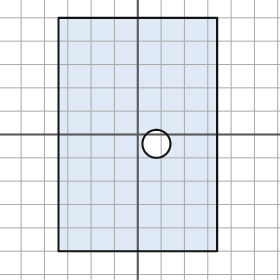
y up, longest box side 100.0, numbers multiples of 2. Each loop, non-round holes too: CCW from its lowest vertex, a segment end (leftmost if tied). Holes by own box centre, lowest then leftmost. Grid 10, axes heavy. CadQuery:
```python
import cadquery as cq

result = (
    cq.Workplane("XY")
    .moveTo(-34.0, -50.0)
    .lineTo(34.0, -50.0)
    .lineTo(34.0, 50.0)
    .lineTo(-34.0, 50.0)
    .close()
    .moveTo(8.0, -4.0)
    .circle(6.0)
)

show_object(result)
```